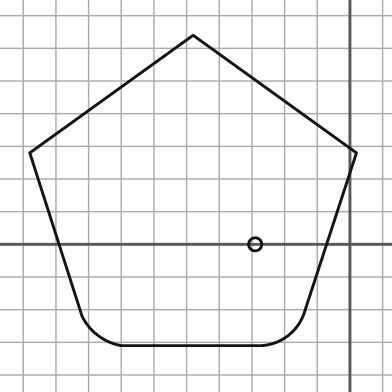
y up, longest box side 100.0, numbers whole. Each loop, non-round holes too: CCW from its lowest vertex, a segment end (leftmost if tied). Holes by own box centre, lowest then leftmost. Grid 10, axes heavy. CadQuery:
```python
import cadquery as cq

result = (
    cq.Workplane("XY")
    .moveTo(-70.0, -31.0)
    .lineTo(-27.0, -31.0)
    .threePointArc((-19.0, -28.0), (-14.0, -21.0))
    .lineTo(2.0, 28.0)
    .lineTo(-48.0, 64.0)
    .lineTo(-98.0, 28.0)
    .lineTo(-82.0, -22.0)
    .threePointArc((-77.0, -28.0), (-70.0, -31.0))
    .close()
    .moveTo(-29.0, 0.0)
    .circle(2.0)
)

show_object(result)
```